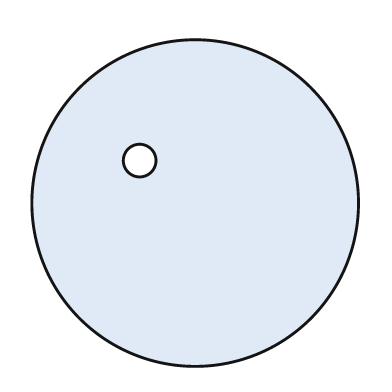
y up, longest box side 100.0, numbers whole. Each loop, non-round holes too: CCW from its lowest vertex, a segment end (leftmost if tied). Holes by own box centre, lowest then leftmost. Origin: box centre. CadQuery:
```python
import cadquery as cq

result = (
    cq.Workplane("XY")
    .moveTo(0.0, 0.0)
    .circle(50.0)
    .moveTo(-17.0, 13.0)
    .circle(5.0)
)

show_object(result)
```